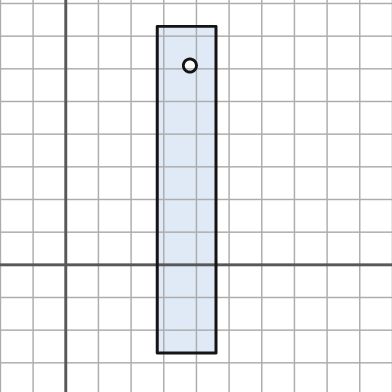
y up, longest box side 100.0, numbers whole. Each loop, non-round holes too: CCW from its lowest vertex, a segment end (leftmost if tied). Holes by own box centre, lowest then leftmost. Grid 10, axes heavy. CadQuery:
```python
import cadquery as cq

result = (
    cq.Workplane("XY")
    .moveTo(28.0, -27.0)
    .lineTo(46.0, -27.0)
    .lineTo(46.0, 73.0)
    .lineTo(28.0, 73.0)
    .close()
    .moveTo(38.0, 61.0)
    .circle(2.0)
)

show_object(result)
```